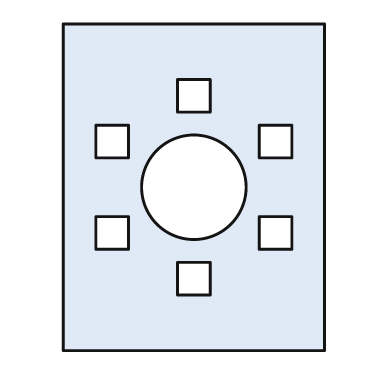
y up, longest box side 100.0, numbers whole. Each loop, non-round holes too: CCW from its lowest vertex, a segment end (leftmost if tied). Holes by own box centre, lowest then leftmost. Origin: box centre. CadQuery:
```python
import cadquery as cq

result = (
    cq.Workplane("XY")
    .moveTo(-40.0, -50.0)
    .lineTo(40.0, -50.0)
    .lineTo(40.0, 50.0)
    .lineTo(-40.0, 50.0)
    .close()
    .moveTo(-5.0, -33.0)
    .lineTo(5.0, -33.0)
    .lineTo(5.0, -23.0)
    .lineTo(-5.0, -23.0)
    .close()
    .moveTo(-30.0, -19.0)
    .lineTo(-20.0, -19.0)
    .lineTo(-20.0, -9.0)
    .lineTo(-30.0, -9.0)
    .close()
    .moveTo(20.0, -19.0)
    .lineTo(30.0, -19.0)
    .lineTo(30.0, -9.0)
    .lineTo(20.0, -9.0)
    .close()
    .moveTo(0.0, 0.0)
    .circle(16.0)
    .moveTo(-30.0, 9.0)
    .lineTo(-20.0, 9.0)
    .lineTo(-20.0, 19.0)
    .lineTo(-30.0, 19.0)
    .close()
    .moveTo(20.0, 9.0)
    .lineTo(30.0, 9.0)
    .lineTo(30.0, 19.0)
    .lineTo(20.0, 19.0)
    .close()
    .moveTo(-5.0, 23.0)
    .lineTo(5.0, 23.0)
    .lineTo(5.0, 33.0)
    .lineTo(-5.0, 33.0)
    .close()
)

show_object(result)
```